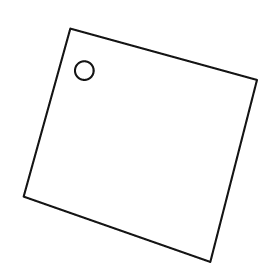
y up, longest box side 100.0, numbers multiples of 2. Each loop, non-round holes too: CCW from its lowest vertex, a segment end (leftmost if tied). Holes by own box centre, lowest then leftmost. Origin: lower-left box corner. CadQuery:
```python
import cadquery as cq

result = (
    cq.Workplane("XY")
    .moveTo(80.0, 0.0)
    .lineTo(100.0, 78.0)
    .lineTo(20.0, 100.0)
    .lineTo(0.0, 28.0)
    .close()
    .moveTo(26.0, 82.0)
    .circle(4.0)
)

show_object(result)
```